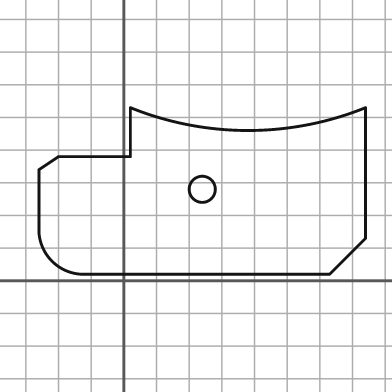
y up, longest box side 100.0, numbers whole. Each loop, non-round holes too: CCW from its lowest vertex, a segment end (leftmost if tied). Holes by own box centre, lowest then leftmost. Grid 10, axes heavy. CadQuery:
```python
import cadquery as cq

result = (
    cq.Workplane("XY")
    .moveTo(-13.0, 2.0)
    .lineTo(63.0, 2.0)
    .lineTo(74.0, 13.0)
    .lineTo(74.0, 53.0)
    .threePointArc((38.0, 46.0), (2.0, 53.0))
    .lineTo(2.0, 38.0)
    .lineTo(-20.0, 38.0)
    .lineTo(-26.0, 34.0)
    .lineTo(-26.0, 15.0)
    .threePointArc((-22.0, 6.0), (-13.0, 2.0))
    .close()
    .moveTo(24.0, 28.0)
    .circle(4.0)
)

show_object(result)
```